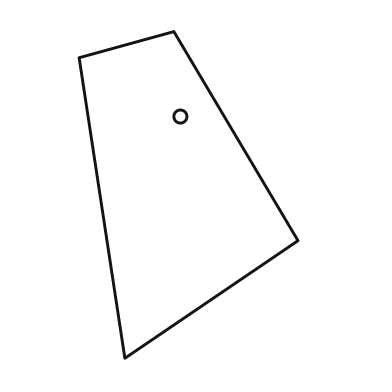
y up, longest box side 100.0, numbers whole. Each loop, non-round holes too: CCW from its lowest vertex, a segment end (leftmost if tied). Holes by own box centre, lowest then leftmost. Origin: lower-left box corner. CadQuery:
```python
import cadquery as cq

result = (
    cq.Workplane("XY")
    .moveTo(14.0, 0.0)
    .lineTo(67.0, 36.0)
    .lineTo(29.0, 100.0)
    .lineTo(0.0, 92.0)
    .close()
    .moveTo(31.0, 74.0)
    .circle(2.0)
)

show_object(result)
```